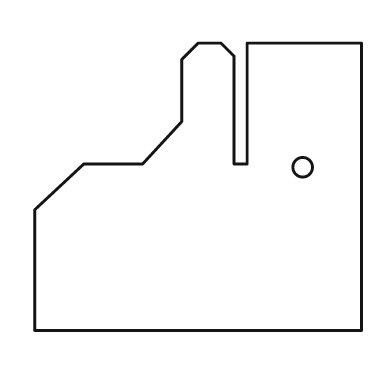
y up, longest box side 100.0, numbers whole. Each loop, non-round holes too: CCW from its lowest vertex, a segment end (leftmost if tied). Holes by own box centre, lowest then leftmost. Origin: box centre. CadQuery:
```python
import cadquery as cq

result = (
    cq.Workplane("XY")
    .moveTo(-50.0, -44.0)
    .lineTo(50.0, -44.0)
    .lineTo(50.0, 44.0)
    .lineTo(15.0, 44.0)
    .lineTo(15.0, 7.0)
    .lineTo(11.0, 7.0)
    .lineTo(11.0, 40.0)
    .lineTo(7.0, 44.0)
    .lineTo(0.0, 44.0)
    .lineTo(-5.0, 39.0)
    .lineTo(-5.0, 20.0)
    .lineTo(-17.0, 7.0)
    .lineTo(-35.0, 7.0)
    .lineTo(-50.0, -7.0)
    .close()
    .moveTo(32.0, 6.0)
    .circle(3.0)
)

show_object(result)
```